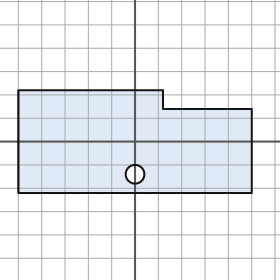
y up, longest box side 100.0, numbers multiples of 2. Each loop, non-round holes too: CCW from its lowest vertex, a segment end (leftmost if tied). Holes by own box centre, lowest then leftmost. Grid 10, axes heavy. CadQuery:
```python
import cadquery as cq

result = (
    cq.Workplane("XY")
    .moveTo(-50.0, -22.0)
    .lineTo(50.0, -22.0)
    .lineTo(50.0, 14.0)
    .lineTo(12.0, 14.0)
    .lineTo(12.0, 22.0)
    .lineTo(-50.0, 22.0)
    .close()
    .moveTo(0.0, -14.0)
    .circle(4.0)
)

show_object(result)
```